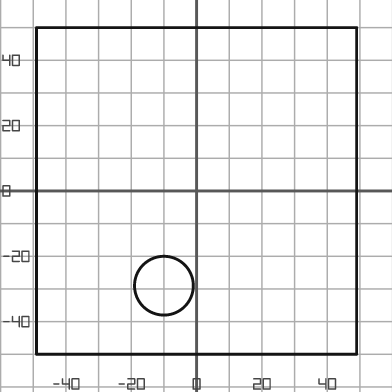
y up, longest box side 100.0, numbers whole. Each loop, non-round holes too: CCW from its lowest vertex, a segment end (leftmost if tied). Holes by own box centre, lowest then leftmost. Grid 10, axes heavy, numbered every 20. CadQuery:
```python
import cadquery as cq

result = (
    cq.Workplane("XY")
    .moveTo(-49.0, -50.0)
    .lineTo(49.0, -50.0)
    .lineTo(49.0, 50.0)
    .lineTo(-49.0, 50.0)
    .close()
    .moveTo(-10.0, -29.0)
    .circle(9.0)
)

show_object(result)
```